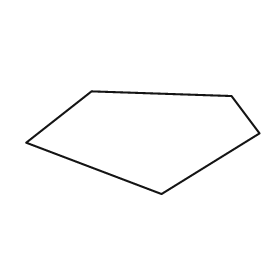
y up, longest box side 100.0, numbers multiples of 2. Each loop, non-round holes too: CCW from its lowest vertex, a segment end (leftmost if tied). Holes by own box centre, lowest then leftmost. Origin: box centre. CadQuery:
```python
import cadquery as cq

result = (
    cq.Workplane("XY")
    .moveTo(8.0, -22.0)
    .lineTo(50.0, 4.0)
    .lineTo(38.0, 20.0)
    .lineTo(-22.0, 22.0)
    .lineTo(-50.0, 0.0)
    .close()
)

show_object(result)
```